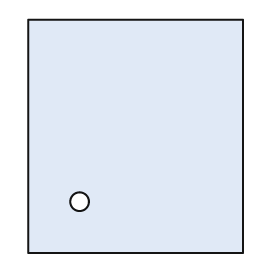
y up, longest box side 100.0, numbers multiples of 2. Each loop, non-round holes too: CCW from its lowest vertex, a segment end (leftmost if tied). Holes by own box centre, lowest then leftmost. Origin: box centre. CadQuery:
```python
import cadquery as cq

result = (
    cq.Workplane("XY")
    .moveTo(-46.0, -50.0)
    .lineTo(46.0, -50.0)
    .lineTo(46.0, 50.0)
    .lineTo(-46.0, 50.0)
    .close()
    .moveTo(-24.0, -28.0)
    .circle(4.0)
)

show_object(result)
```